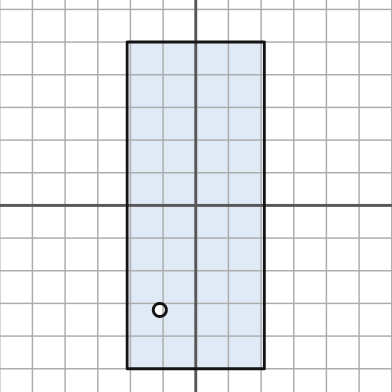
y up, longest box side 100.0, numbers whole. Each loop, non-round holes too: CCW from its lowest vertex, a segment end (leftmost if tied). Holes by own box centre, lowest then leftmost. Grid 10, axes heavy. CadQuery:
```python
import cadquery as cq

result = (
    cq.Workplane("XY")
    .moveTo(-21.0, -50.0)
    .lineTo(21.0, -50.0)
    .lineTo(21.0, 50.0)
    .lineTo(-21.0, 50.0)
    .close()
    .moveTo(-11.0, -32.0)
    .circle(2.0)
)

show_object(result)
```